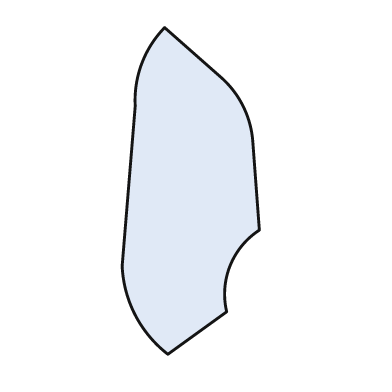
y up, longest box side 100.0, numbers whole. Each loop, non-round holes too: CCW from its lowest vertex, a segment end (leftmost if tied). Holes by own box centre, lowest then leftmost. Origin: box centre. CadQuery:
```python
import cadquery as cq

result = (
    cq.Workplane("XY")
    .moveTo(-7.0, -50.0)
    .lineTo(11.0, -37.0)
    .threePointArc((12.0, -23.0), (21.0, -12.0))
    .lineTo(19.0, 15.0)
    .threePointArc((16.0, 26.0), (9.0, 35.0))
    .lineTo(-8.0, 50.0)
    .threePointArc((-15.0, 39.0), (-17.0, 26.0))
    .lineTo(-21.0, -23.0)
    .threePointArc((-17.0, -38.0), (-7.0, -50.0))
    .close()
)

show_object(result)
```